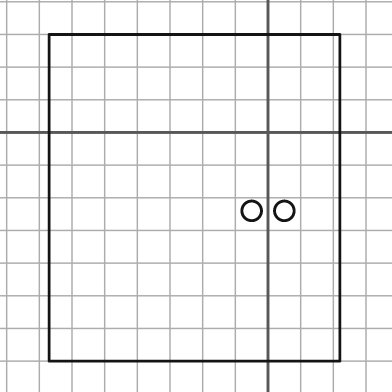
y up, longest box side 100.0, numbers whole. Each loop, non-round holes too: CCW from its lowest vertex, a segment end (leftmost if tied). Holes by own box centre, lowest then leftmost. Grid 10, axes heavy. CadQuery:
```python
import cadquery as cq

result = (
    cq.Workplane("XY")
    .moveTo(-67.0, -70.0)
    .lineTo(22.0, -70.0)
    .lineTo(22.0, 30.0)
    .lineTo(-67.0, 30.0)
    .close()
    .moveTo(-5.0, -24.0)
    .circle(3.0)
    .moveTo(5.0, -24.0)
    .circle(3.0)
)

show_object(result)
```